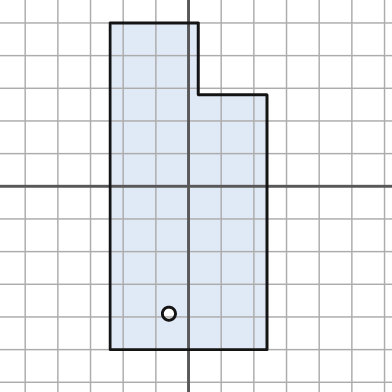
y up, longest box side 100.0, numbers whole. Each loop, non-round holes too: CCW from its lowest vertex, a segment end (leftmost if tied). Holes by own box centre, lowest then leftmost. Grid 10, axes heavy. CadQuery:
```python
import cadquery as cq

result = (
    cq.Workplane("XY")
    .moveTo(-24.0, -50.0)
    .lineTo(24.0, -50.0)
    .lineTo(24.0, 28.0)
    .lineTo(3.0, 28.0)
    .lineTo(3.0, 50.0)
    .lineTo(-24.0, 50.0)
    .close()
    .moveTo(-6.0, -39.0)
    .circle(2.0)
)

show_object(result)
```